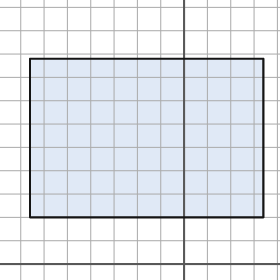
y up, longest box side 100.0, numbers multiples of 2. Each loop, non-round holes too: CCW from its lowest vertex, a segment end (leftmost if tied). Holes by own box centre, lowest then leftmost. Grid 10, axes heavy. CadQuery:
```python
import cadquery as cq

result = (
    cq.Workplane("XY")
    .moveTo(-66.0, 20.0)
    .lineTo(34.0, 20.0)
    .lineTo(34.0, 88.0)
    .lineTo(-66.0, 88.0)
    .close()
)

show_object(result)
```